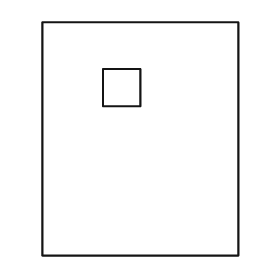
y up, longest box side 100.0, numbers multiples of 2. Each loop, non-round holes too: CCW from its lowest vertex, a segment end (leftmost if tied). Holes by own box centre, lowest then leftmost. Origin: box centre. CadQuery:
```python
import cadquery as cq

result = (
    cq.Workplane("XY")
    .moveTo(-42.0, -50.0)
    .lineTo(42.0, -50.0)
    .lineTo(42.0, 50.0)
    .lineTo(-42.0, 50.0)
    .close()
    .moveTo(-16.0, 14.0)
    .lineTo(0.0, 14.0)
    .lineTo(0.0, 30.0)
    .lineTo(-16.0, 30.0)
    .close()
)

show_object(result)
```